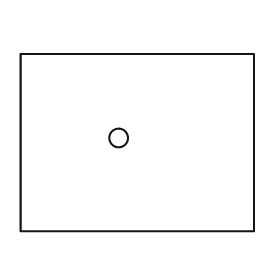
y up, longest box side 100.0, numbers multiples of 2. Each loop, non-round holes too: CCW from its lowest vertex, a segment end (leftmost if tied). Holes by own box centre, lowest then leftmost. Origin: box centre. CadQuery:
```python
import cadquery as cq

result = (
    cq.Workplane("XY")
    .moveTo(-50.0, -38.0)
    .lineTo(50.0, -38.0)
    .lineTo(50.0, 38.0)
    .lineTo(-50.0, 38.0)
    .close()
    .moveTo(-8.0, 2.0)
    .circle(4.0)
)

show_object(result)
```